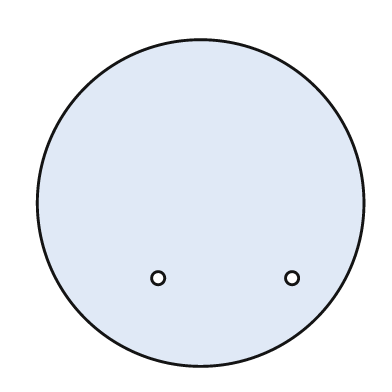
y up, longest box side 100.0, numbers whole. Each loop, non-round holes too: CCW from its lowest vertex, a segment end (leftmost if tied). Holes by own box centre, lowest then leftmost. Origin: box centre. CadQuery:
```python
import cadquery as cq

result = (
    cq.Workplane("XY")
    .moveTo(0.0, 0.0)
    .circle(50.0)
    .moveTo(-13.0, -23.0)
    .circle(2.0)
    .moveTo(28.0, -23.0)
    .circle(2.0)
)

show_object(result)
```